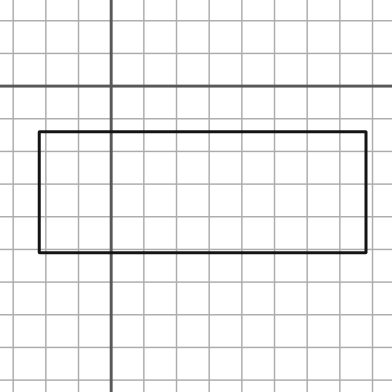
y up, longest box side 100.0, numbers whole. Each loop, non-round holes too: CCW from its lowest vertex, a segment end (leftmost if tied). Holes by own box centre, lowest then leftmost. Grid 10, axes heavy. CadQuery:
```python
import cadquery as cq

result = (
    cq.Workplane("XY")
    .moveTo(-22.0, -51.0)
    .lineTo(78.0, -51.0)
    .lineTo(78.0, -14.0)
    .lineTo(-22.0, -14.0)
    .close()
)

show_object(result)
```